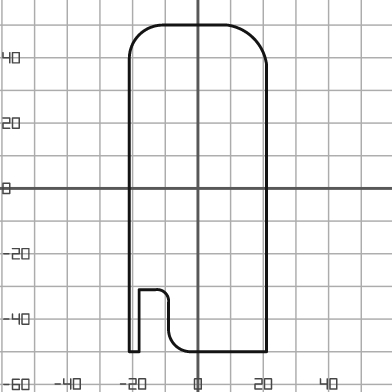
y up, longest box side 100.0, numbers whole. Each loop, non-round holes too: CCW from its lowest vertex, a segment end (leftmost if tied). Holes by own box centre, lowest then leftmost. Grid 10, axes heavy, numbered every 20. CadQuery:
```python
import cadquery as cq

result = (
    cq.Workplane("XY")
    .moveTo(-21.0, -50.0)
    .lineTo(-18.0, -50.0)
    .lineTo(-18.0, -31.0)
    .lineTo(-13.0, -31.0)
    .threePointArc((-10.0, -32.0), (-9.0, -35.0))
    .lineTo(-9.0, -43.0)
    .threePointArc((-7.0, -48.0), (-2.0, -50.0))
    .lineTo(21.0, -50.0)
    .lineTo(21.0, 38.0)
    .threePointArc((17.0, 46.0), (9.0, 50.0))
    .lineTo(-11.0, 50.0)
    .threePointArc((-18.0, 47.0), (-21.0, 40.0))
    .close()
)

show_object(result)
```